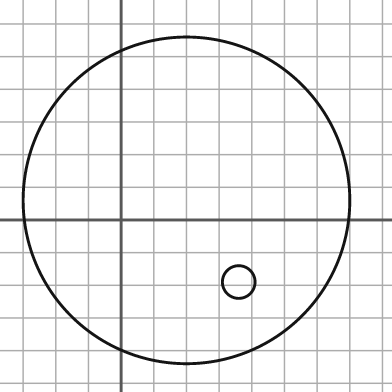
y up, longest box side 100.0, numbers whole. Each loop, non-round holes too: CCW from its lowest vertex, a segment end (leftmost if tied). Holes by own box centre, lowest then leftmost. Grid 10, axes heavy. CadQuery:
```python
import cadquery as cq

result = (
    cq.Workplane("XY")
    .moveTo(20.0, 6.0)
    .circle(50.0)
    .moveTo(36.0, -19.0)
    .circle(5.0)
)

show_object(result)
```